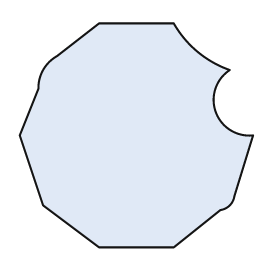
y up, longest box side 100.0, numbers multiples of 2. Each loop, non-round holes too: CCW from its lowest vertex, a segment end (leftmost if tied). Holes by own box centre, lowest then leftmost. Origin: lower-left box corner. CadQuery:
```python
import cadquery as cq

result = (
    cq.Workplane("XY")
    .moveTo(34.0, 0.0)
    .lineTo(66.0, 0.0)
    .lineTo(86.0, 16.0)
    .threePointArc((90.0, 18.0), (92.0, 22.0))
    .lineTo(100.0, 48.0)
    .threePointArc((84.0, 58.0), (90.0, 76.0))
    .threePointArc((76.0, 84.0), (66.0, 96.0))
    .lineTo(34.0, 96.0)
    .lineTo(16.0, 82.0)
    .threePointArc((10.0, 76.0), (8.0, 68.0))
    .lineTo(0.0, 48.0)
    .lineTo(10.0, 18.0)
    .close()
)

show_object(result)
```